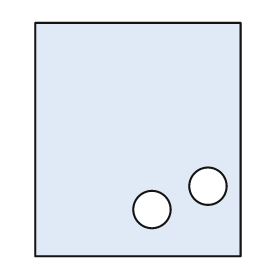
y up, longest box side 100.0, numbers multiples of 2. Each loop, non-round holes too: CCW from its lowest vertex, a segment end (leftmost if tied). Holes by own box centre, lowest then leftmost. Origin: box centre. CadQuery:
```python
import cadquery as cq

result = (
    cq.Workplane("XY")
    .moveTo(-44.0, -50.0)
    .lineTo(44.0, -50.0)
    .lineTo(44.0, 50.0)
    .lineTo(-44.0, 50.0)
    .close()
    .moveTo(6.0, -30.0)
    .circle(8.0)
    .moveTo(30.0, -20.0)
    .circle(8.0)
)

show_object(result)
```